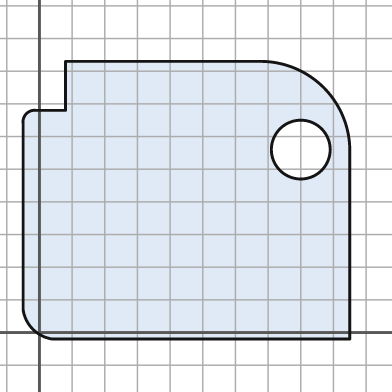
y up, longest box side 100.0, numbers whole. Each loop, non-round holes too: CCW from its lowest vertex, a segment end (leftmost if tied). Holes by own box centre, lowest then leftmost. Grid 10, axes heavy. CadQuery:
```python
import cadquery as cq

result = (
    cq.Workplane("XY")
    .moveTo(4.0, -2.0)
    .lineTo(95.0, -2.0)
    .lineTo(95.0, 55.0)
    .threePointArc((87.0, 75.0), (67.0, 83.0))
    .lineTo(8.0, 83.0)
    .lineTo(8.0, 68.0)
    .lineTo(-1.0, 68.0)
    .threePointArc((-4.0, 67.0), (-5.0, 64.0))
    .lineTo(-5.0, 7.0)
    .threePointArc((-2.0, 1.0), (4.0, -2.0))
    .close()
    .moveTo(80.0, 56.0)
    .circle(9.0)
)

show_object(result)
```